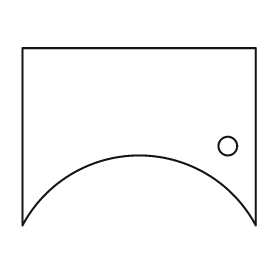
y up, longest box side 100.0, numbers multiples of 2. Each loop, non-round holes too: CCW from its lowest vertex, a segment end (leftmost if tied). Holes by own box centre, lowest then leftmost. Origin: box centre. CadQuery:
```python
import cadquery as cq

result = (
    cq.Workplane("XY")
    .moveTo(-50.0, -38.0)
    .threePointArc((0.0, -8.0), (50.0, -38.0))
    .lineTo(50.0, 38.0)
    .lineTo(-50.0, 38.0)
    .close()
    .moveTo(38.0, -4.0)
    .circle(4.0)
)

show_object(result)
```